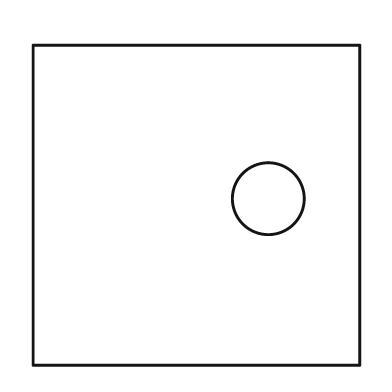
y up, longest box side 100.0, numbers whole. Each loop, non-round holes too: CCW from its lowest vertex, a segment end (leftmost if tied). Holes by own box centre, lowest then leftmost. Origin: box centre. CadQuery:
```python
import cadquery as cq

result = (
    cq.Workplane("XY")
    .moveTo(-50.0, -49.0)
    .lineTo(50.0, -49.0)
    .lineTo(50.0, 49.0)
    .lineTo(-50.0, 49.0)
    .close()
    .moveTo(22.0, 2.0)
    .circle(11.0)
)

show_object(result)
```